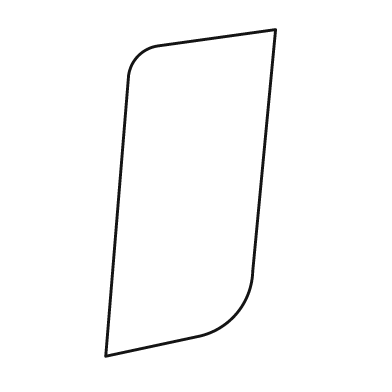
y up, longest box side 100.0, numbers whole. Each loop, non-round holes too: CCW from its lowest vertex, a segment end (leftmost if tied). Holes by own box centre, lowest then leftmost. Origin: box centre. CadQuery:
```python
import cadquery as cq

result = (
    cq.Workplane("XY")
    .moveTo(-26.0, -50.0)
    .lineTo(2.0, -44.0)
    .threePointArc((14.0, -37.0), (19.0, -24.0))
    .lineTo(26.0, 50.0)
    .lineTo(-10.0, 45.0)
    .threePointArc((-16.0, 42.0), (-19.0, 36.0))
    .close()
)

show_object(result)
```